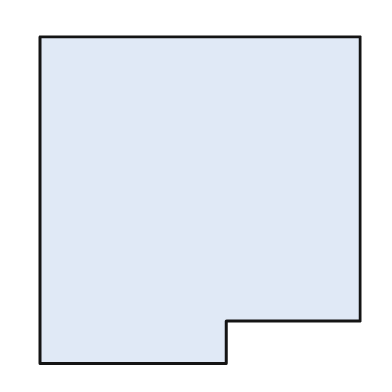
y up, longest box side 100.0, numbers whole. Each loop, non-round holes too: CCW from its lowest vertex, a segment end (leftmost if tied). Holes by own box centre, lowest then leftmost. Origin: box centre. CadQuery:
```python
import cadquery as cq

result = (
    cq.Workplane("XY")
    .moveTo(-49.0, -50.0)
    .lineTo(8.0, -50.0)
    .lineTo(8.0, -37.0)
    .lineTo(49.0, -37.0)
    .lineTo(49.0, 50.0)
    .lineTo(-49.0, 50.0)
    .close()
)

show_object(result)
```